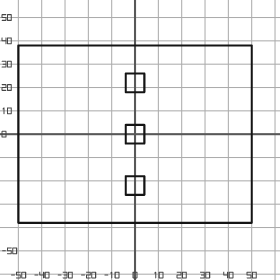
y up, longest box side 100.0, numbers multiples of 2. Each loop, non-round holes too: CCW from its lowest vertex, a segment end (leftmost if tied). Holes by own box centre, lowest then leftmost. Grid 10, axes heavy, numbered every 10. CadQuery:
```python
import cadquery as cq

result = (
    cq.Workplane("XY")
    .moveTo(-50.0, -38.0)
    .lineTo(50.0, -38.0)
    .lineTo(50.0, 38.0)
    .lineTo(-50.0, 38.0)
    .close()
    .moveTo(-4.0, -26.0)
    .lineTo(4.0, -26.0)
    .lineTo(4.0, -18.0)
    .lineTo(-4.0, -18.0)
    .close()
    .moveTo(-4.0, -4.0)
    .lineTo(4.0, -4.0)
    .lineTo(4.0, 4.0)
    .lineTo(-4.0, 4.0)
    .close()
    .moveTo(-4.0, 18.0)
    .lineTo(4.0, 18.0)
    .lineTo(4.0, 26.0)
    .lineTo(-4.0, 26.0)
    .close()
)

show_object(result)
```